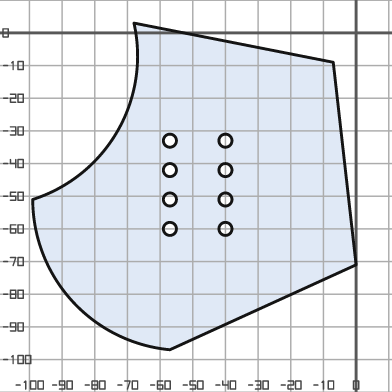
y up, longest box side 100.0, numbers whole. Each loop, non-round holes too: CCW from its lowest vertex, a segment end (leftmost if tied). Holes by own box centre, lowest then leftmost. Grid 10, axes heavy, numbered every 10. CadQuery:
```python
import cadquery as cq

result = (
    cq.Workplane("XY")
    .moveTo(-57.0, -97.0)
    .lineTo(0.0, -71.0)
    .lineTo(-7.0, -9.0)
    .lineTo(-68.0, 3.0)
    .threePointArc((-73.0, -30.0), (-99.0, -51.0))
    .threePointArc((-87.0, -82.0), (-57.0, -97.0))
    .close()
    .moveTo(-57.0, -60.0)
    .circle(2.0)
    .moveTo(-40.0, -60.0)
    .circle(2.0)
    .moveTo(-57.0, -51.0)
    .circle(2.0)
    .moveTo(-40.0, -51.0)
    .circle(2.0)
    .moveTo(-57.0, -42.0)
    .circle(2.0)
    .moveTo(-40.0, -42.0)
    .circle(2.0)
    .moveTo(-57.0, -33.0)
    .circle(2.0)
    .moveTo(-40.0, -33.0)
    .circle(2.0)
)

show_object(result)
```